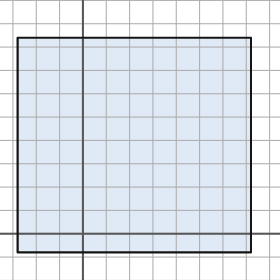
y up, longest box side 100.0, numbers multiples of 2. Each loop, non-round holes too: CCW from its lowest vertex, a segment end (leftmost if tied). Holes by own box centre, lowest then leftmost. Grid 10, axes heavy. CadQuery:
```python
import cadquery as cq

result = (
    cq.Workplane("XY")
    .moveTo(-28.0, -8.0)
    .lineTo(72.0, -8.0)
    .lineTo(72.0, 84.0)
    .lineTo(-28.0, 84.0)
    .close()
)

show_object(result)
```